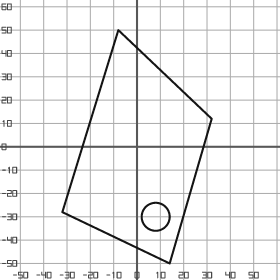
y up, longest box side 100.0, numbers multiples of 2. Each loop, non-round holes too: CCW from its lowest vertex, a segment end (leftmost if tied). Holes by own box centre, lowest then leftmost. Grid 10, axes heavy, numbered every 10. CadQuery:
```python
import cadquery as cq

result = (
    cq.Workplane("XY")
    .moveTo(14.0, -50.0)
    .lineTo(32.0, 12.0)
    .lineTo(-8.0, 50.0)
    .lineTo(-32.0, -28.0)
    .close()
    .moveTo(8.0, -30.0)
    .circle(6.0)
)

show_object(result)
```